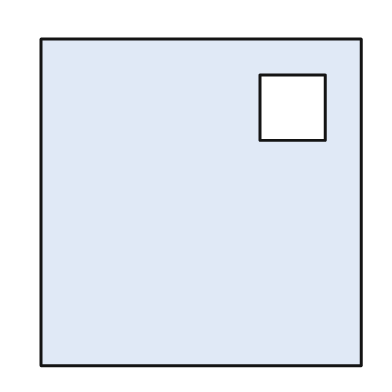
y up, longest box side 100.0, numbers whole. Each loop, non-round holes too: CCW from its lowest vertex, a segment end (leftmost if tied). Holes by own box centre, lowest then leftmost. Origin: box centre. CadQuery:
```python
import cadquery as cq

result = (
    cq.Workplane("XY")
    .moveTo(-49.0, -50.0)
    .lineTo(49.0, -50.0)
    .lineTo(49.0, 50.0)
    .lineTo(-49.0, 50.0)
    .close()
    .moveTo(18.0, 19.0)
    .lineTo(38.0, 19.0)
    .lineTo(38.0, 39.0)
    .lineTo(18.0, 39.0)
    .close()
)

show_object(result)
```